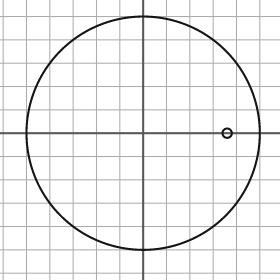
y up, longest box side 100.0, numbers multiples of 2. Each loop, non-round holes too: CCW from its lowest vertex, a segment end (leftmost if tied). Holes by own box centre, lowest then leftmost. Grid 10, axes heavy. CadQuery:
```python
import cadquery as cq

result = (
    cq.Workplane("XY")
    .moveTo(0.0, 0.0)
    .circle(50.0)
    .moveTo(36.0, 0.0)
    .circle(2.0)
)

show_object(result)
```